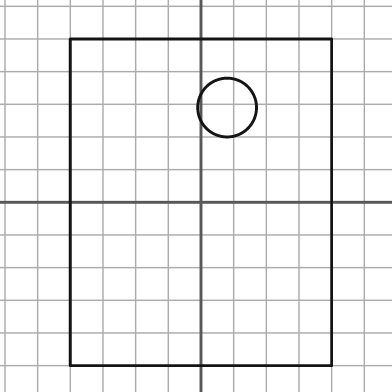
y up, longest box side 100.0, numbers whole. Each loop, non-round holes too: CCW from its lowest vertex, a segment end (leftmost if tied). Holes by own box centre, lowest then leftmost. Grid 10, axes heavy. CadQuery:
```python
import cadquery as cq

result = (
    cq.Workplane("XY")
    .moveTo(-40.0, -50.0)
    .lineTo(40.0, -50.0)
    .lineTo(40.0, 50.0)
    .lineTo(-40.0, 50.0)
    .close()
    .moveTo(8.0, 29.0)
    .circle(9.0)
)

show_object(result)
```